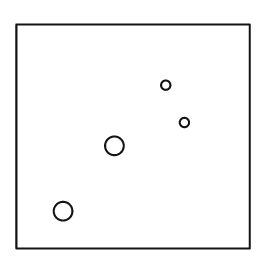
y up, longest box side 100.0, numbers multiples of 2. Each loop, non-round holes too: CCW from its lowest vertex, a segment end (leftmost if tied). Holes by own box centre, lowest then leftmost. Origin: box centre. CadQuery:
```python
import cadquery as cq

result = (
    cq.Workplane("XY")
    .moveTo(-50.0, -48.0)
    .lineTo(50.0, -48.0)
    .lineTo(50.0, 48.0)
    .lineTo(-50.0, 48.0)
    .close()
    .moveTo(-30.0, -32.0)
    .circle(4.0)
    .moveTo(-8.0, -4.0)
    .circle(4.0)
    .moveTo(22.0, 6.0)
    .circle(2.0)
    .moveTo(14.0, 22.0)
    .circle(2.0)
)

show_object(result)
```